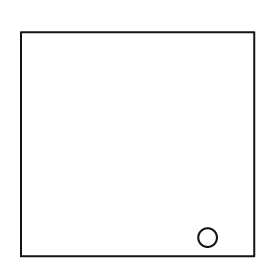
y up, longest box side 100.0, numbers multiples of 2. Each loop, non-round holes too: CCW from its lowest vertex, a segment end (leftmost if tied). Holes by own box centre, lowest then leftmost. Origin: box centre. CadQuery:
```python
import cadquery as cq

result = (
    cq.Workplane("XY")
    .moveTo(-50.0, -48.0)
    .lineTo(50.0, -48.0)
    .lineTo(50.0, 48.0)
    .lineTo(-50.0, 48.0)
    .close()
    .moveTo(30.0, -40.0)
    .circle(4.0)
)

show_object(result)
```